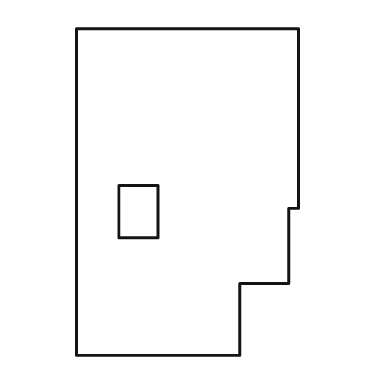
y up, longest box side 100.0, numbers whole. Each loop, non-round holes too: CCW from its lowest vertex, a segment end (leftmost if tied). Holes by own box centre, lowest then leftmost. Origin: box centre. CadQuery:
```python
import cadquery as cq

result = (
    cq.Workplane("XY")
    .moveTo(-34.0, -50.0)
    .lineTo(16.0, -50.0)
    .lineTo(16.0, -28.0)
    .lineTo(31.0, -28.0)
    .lineTo(31.0, -5.0)
    .lineTo(34.0, -5.0)
    .lineTo(34.0, 50.0)
    .lineTo(-34.0, 50.0)
    .close()
    .moveTo(-21.0, -14.0)
    .lineTo(-9.0, -14.0)
    .lineTo(-9.0, 2.0)
    .lineTo(-21.0, 2.0)
    .close()
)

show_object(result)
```